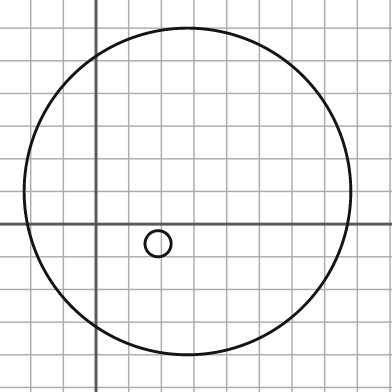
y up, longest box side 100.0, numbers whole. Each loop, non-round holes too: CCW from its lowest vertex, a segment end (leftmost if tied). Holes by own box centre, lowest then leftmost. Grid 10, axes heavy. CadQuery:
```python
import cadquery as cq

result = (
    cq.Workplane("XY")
    .moveTo(28.0, 10.0)
    .circle(50.0)
    .moveTo(19.0, -6.0)
    .circle(4.0)
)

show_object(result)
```